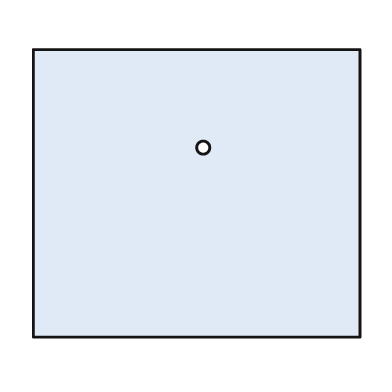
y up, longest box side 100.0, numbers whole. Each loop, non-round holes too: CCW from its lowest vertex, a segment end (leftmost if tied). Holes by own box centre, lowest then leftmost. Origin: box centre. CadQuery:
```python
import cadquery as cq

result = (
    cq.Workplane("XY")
    .moveTo(-50.0, -44.0)
    .lineTo(50.0, -44.0)
    .lineTo(50.0, 44.0)
    .lineTo(-50.0, 44.0)
    .close()
    .moveTo(2.0, 14.0)
    .circle(2.0)
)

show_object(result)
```